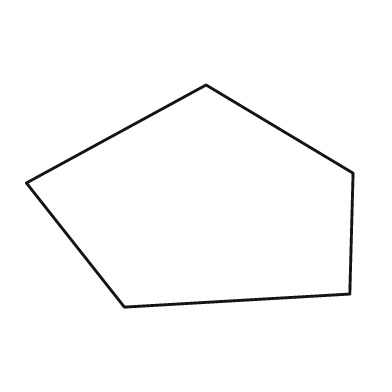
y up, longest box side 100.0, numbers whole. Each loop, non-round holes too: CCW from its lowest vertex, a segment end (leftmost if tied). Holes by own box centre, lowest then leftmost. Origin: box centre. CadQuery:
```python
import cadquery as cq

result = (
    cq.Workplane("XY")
    .moveTo(-20.0, -34.0)
    .lineTo(49.0, -30.0)
    .lineTo(50.0, 7.0)
    .lineTo(5.0, 34.0)
    .lineTo(-50.0, 4.0)
    .close()
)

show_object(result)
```